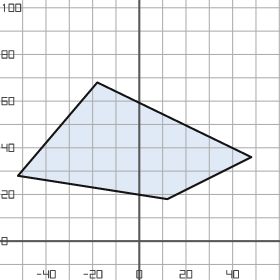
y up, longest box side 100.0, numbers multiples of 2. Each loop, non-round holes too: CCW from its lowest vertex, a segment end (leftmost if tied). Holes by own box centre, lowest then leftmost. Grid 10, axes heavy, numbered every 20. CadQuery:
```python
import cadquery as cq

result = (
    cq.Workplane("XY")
    .moveTo(12.0, 18.0)
    .lineTo(48.0, 36.0)
    .lineTo(-18.0, 68.0)
    .lineTo(-52.0, 28.0)
    .close()
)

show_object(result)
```